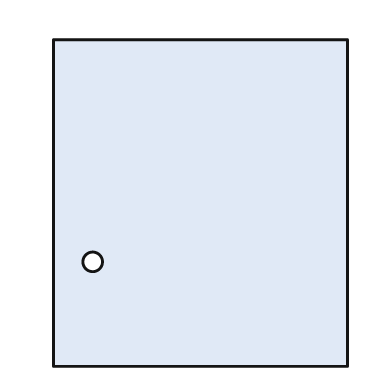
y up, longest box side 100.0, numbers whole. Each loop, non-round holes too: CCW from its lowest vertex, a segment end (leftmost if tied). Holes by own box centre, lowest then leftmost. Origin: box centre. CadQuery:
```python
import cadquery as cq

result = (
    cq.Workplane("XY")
    .moveTo(-45.0, -50.0)
    .lineTo(45.0, -50.0)
    .lineTo(45.0, 50.0)
    .lineTo(-45.0, 50.0)
    .close()
    .moveTo(-33.0, -18.0)
    .circle(3.0)
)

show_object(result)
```